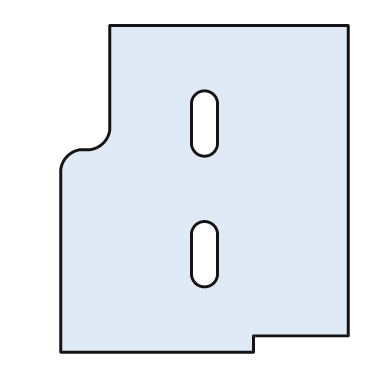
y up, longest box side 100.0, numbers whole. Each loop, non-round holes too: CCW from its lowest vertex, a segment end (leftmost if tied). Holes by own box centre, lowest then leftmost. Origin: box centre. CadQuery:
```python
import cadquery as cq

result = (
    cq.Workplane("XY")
    .moveTo(-44.0, -50.0)
    .lineTo(15.0, -50.0)
    .lineTo(15.0, -45.0)
    .lineTo(44.0, -45.0)
    .lineTo(44.0, 50.0)
    .lineTo(-29.0, 50.0)
    .lineTo(-29.0, 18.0)
    .threePointArc((-31.0, 14.0), (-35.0, 12.0))
    .lineTo(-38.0, 12.0)
    .threePointArc((-42.0, 10.0), (-44.0, 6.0))
    .close()
    .moveTo(-4.0, -26.0)
    .threePointArc((0.0, -30.0), (4.0, -26.0))
    .lineTo(4.0, -14.0)
    .threePointArc((0.0, -10.0), (-4.0, -14.0))
    .close()
    .moveTo(-4.0, 14.0)
    .threePointArc((0.0, 10.0), (4.0, 14.0))
    .lineTo(4.0, 26.0)
    .threePointArc((0.0, 30.0), (-4.0, 26.0))
    .close()
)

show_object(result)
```